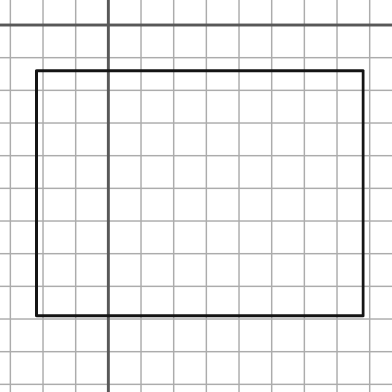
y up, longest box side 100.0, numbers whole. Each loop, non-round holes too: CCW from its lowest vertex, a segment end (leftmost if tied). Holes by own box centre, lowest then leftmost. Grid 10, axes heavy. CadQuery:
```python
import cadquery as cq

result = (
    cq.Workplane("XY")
    .moveTo(-22.0, -89.0)
    .lineTo(78.0, -89.0)
    .lineTo(78.0, -14.0)
    .lineTo(-22.0, -14.0)
    .close()
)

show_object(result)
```